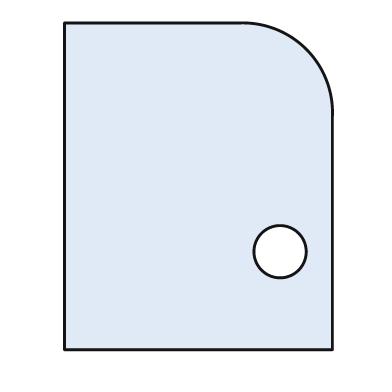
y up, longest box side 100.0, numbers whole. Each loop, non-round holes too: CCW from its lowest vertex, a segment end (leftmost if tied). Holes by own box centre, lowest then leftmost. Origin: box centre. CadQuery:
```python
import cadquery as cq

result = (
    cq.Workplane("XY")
    .moveTo(-41.0, -50.0)
    .lineTo(41.0, -50.0)
    .lineTo(41.0, 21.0)
    .threePointArc((33.0, 42.0), (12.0, 50.0))
    .lineTo(-41.0, 50.0)
    .close()
    .moveTo(25.0, -20.0)
    .circle(8.0)
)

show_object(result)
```